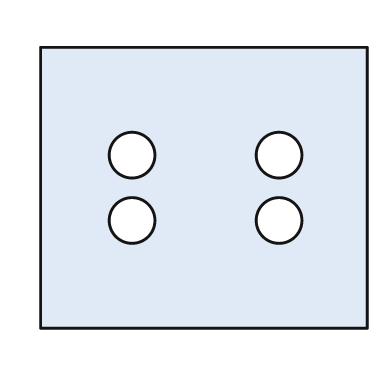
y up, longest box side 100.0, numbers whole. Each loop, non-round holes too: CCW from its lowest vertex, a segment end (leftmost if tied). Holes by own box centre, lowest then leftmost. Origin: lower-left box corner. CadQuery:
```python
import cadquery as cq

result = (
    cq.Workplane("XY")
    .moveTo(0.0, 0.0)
    .lineTo(100.0, 0.0)
    .lineTo(100.0, 86.0)
    .lineTo(0.0, 86.0)
    .close()
    .moveTo(28.0, 33.0)
    .circle(7.0)
    .moveTo(73.0, 33.0)
    .circle(7.0)
    .moveTo(28.0, 53.0)
    .circle(7.0)
    .moveTo(73.0, 53.0)
    .circle(7.0)
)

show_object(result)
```